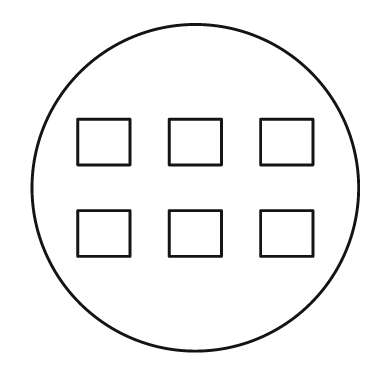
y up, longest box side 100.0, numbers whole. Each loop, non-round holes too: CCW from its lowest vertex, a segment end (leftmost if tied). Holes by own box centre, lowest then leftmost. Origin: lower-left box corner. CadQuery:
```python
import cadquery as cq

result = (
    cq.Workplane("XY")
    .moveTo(50.0, 50.0)
    .circle(50.0)
    .moveTo(14.0, 29.0)
    .lineTo(30.0, 29.0)
    .lineTo(30.0, 43.0)
    .lineTo(14.0, 43.0)
    .close()
    .moveTo(42.0, 29.0)
    .lineTo(58.0, 29.0)
    .lineTo(58.0, 43.0)
    .lineTo(42.0, 43.0)
    .close()
    .moveTo(70.0, 29.0)
    .lineTo(86.0, 29.0)
    .lineTo(86.0, 43.0)
    .lineTo(70.0, 43.0)
    .close()
    .moveTo(14.0, 57.0)
    .lineTo(30.0, 57.0)
    .lineTo(30.0, 71.0)
    .lineTo(14.0, 71.0)
    .close()
    .moveTo(42.0, 57.0)
    .lineTo(58.0, 57.0)
    .lineTo(58.0, 71.0)
    .lineTo(42.0, 71.0)
    .close()
    .moveTo(70.0, 57.0)
    .lineTo(86.0, 57.0)
    .lineTo(86.0, 71.0)
    .lineTo(70.0, 71.0)
    .close()
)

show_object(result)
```